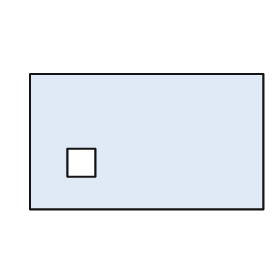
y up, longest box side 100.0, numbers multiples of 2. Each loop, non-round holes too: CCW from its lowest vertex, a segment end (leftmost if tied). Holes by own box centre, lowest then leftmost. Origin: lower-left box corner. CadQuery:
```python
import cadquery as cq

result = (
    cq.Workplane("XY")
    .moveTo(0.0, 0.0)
    .lineTo(100.0, 0.0)
    .lineTo(100.0, 58.0)
    .lineTo(0.0, 58.0)
    .close()
    .moveTo(16.0, 14.0)
    .lineTo(28.0, 14.0)
    .lineTo(28.0, 26.0)
    .lineTo(16.0, 26.0)
    .close()
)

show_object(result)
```